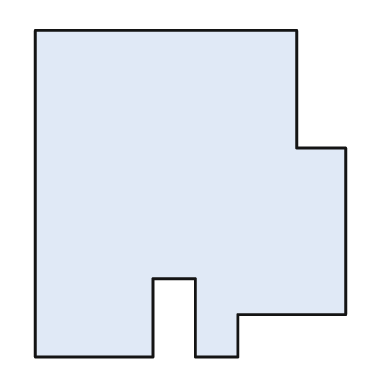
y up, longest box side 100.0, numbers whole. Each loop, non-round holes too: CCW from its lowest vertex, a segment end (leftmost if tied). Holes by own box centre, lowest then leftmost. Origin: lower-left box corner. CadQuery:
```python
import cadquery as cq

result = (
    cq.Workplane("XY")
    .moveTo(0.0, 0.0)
    .lineTo(36.0, 0.0)
    .lineTo(36.0, 24.0)
    .lineTo(49.0, 24.0)
    .lineTo(49.0, 0.0)
    .lineTo(62.0, 0.0)
    .lineTo(62.0, 13.0)
    .lineTo(95.0, 13.0)
    .lineTo(95.0, 64.0)
    .lineTo(80.0, 64.0)
    .lineTo(80.0, 100.0)
    .lineTo(0.0, 100.0)
    .close()
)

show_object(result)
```